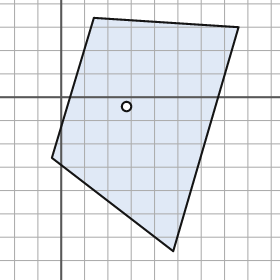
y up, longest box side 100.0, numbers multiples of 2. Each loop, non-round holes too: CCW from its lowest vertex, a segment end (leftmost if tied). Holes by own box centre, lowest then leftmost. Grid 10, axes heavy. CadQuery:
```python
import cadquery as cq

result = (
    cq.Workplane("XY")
    .moveTo(48.0, -66.0)
    .lineTo(76.0, 30.0)
    .lineTo(14.0, 34.0)
    .lineTo(-4.0, -26.0)
    .close()
    .moveTo(28.0, -4.0)
    .circle(2.0)
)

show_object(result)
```